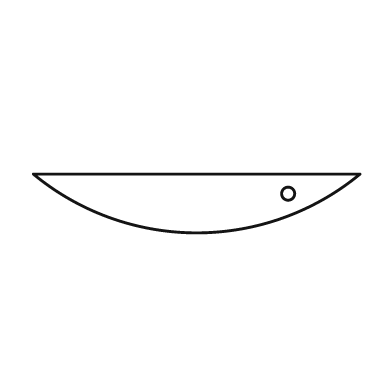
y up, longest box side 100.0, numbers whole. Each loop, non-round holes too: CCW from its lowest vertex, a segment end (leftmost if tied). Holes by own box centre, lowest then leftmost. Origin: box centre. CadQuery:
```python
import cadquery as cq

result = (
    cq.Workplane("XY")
    .moveTo(-50.0, 9.0)
    .threePointArc((0.0, -9.0), (50.0, 9.0))
    .close()
    .moveTo(28.0, 3.0)
    .circle(2.0)
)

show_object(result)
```